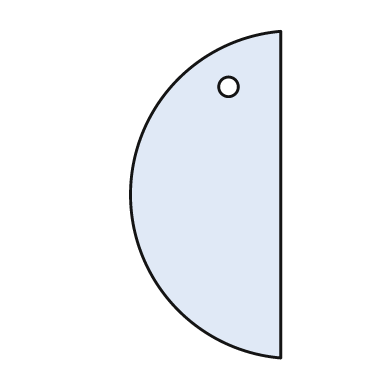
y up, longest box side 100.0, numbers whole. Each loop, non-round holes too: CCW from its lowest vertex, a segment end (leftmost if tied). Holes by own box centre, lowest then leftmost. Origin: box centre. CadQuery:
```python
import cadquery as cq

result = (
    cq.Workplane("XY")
    .moveTo(23.0, -50.0)
    .lineTo(23.0, 50.0)
    .threePointArc((-23.0, 0.0), (23.0, -50.0))
    .close()
    .moveTo(7.0, 33.0)
    .circle(3.0)
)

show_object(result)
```